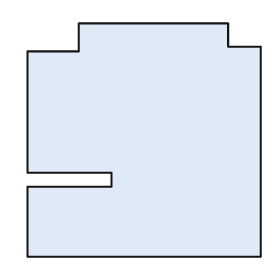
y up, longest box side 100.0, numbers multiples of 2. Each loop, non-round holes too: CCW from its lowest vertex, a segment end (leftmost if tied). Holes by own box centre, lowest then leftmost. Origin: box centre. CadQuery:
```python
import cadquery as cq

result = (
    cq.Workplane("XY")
    .moveTo(-50.0, -50.0)
    .lineTo(50.0, -50.0)
    .lineTo(50.0, 40.0)
    .lineTo(36.0, 40.0)
    .lineTo(36.0, 50.0)
    .lineTo(-28.0, 50.0)
    .lineTo(-28.0, 38.0)
    .lineTo(-50.0, 38.0)
    .lineTo(-50.0, -14.0)
    .lineTo(-14.0, -14.0)
    .lineTo(-14.0, -20.0)
    .lineTo(-50.0, -20.0)
    .close()
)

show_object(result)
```